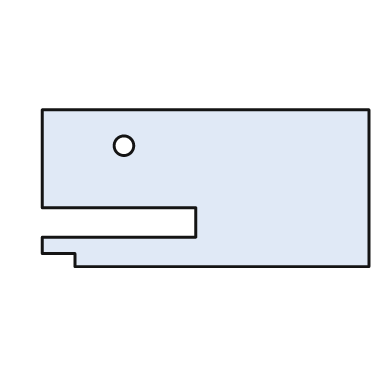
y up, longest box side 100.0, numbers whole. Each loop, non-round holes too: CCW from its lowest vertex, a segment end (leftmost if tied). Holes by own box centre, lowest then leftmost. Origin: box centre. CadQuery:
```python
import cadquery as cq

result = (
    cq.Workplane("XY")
    .moveTo(-40.0, -24.0)
    .lineTo(50.0, -24.0)
    .lineTo(50.0, 24.0)
    .lineTo(-50.0, 24.0)
    .lineTo(-50.0, -6.0)
    .lineTo(-3.0, -6.0)
    .lineTo(-3.0, -15.0)
    .lineTo(-50.0, -15.0)
    .lineTo(-50.0, -20.0)
    .lineTo(-40.0, -20.0)
    .close()
    .moveTo(-25.0, 13.0)
    .circle(3.0)
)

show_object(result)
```